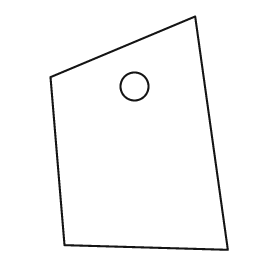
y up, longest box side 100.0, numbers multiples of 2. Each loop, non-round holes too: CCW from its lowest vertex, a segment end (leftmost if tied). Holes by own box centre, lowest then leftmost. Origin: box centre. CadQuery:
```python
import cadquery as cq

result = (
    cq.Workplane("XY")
    .moveTo(38.0, -50.0)
    .lineTo(24.0, 50.0)
    .lineTo(-38.0, 24.0)
    .lineTo(-32.0, -48.0)
    .close()
    .moveTo(-2.0, 20.0)
    .circle(6.0)
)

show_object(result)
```